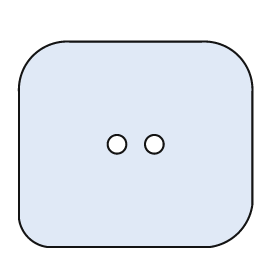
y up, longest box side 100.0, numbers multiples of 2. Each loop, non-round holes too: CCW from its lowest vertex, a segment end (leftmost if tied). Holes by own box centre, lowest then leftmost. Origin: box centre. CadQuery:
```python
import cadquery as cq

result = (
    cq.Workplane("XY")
    .moveTo(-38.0, -44.0)
    .lineTo(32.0, -44.0)
    .threePointArc((44.0, -38.0), (50.0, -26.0))
    .lineTo(50.0, 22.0)
    .threePointArc((44.0, 38.0), (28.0, 44.0))
    .lineTo(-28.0, 44.0)
    .threePointArc((-44.0, 38.0), (-50.0, 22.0))
    .lineTo(-50.0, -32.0)
    .threePointArc((-46.0, -40.0), (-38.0, -44.0))
    .close()
    .moveTo(-8.0, 0.0)
    .circle(4.0)
    .moveTo(8.0, 0.0)
    .circle(4.0)
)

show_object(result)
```